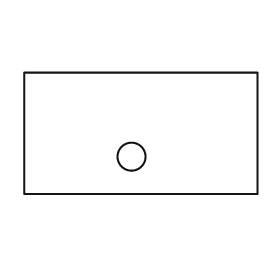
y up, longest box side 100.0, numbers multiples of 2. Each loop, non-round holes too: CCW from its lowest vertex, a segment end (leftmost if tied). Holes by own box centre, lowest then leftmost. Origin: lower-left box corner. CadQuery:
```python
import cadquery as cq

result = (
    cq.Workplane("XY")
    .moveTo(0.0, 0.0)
    .lineTo(100.0, 0.0)
    .lineTo(100.0, 52.0)
    .lineTo(0.0, 52.0)
    .close()
    .moveTo(46.0, 16.0)
    .circle(6.0)
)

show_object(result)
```